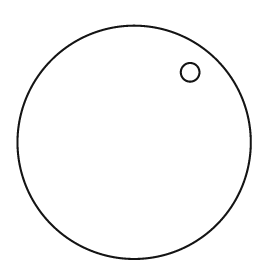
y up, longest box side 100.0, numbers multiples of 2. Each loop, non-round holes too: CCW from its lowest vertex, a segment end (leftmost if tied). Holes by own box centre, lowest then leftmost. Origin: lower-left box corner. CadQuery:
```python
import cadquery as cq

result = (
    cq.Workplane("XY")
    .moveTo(50.0, 50.0)
    .circle(50.0)
    .moveTo(74.0, 80.0)
    .circle(4.0)
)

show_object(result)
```